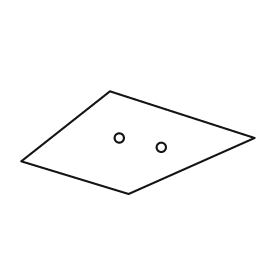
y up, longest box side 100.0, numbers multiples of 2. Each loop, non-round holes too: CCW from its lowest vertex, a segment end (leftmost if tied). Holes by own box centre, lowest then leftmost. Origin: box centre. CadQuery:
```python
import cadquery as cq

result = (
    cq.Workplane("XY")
    .moveTo(-4.0, -22.0)
    .lineTo(50.0, 2.0)
    .lineTo(-12.0, 22.0)
    .lineTo(-50.0, -8.0)
    .close()
    .moveTo(10.0, -2.0)
    .circle(2.0)
    .moveTo(-8.0, 2.0)
    .circle(2.0)
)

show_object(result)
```